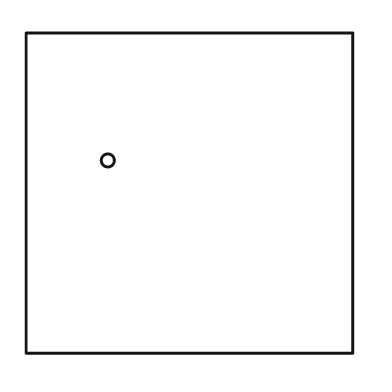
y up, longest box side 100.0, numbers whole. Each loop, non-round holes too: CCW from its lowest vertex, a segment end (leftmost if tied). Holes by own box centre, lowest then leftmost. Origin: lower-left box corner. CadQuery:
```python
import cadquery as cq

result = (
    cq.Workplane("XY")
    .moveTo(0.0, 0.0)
    .lineTo(100.0, 0.0)
    .lineTo(100.0, 98.0)
    .lineTo(0.0, 98.0)
    .close()
    .moveTo(25.0, 59.0)
    .circle(2.0)
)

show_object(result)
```